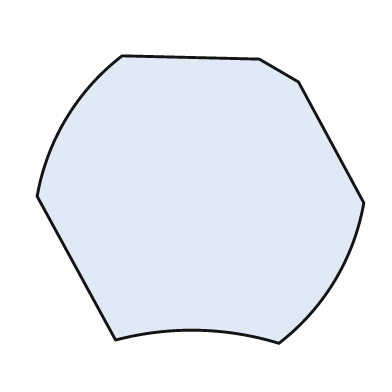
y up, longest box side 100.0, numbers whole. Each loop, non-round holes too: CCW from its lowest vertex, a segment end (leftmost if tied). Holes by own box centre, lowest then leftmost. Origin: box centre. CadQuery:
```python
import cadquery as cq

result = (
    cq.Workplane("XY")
    .moveTo(24.0, -44.0)
    .threePointArc((41.0, -25.0), (50.0, -1.0))
    .lineTo(30.0, 36.0)
    .lineTo(18.0, 43.0)
    .lineTo(-24.0, 44.0)
    .threePointArc((-41.0, 25.0), (-50.0, 1.0))
    .lineTo(-26.0, -43.0)
    .threePointArc((-1.0, -40.0), (24.0, -44.0))
    .close()
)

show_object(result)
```